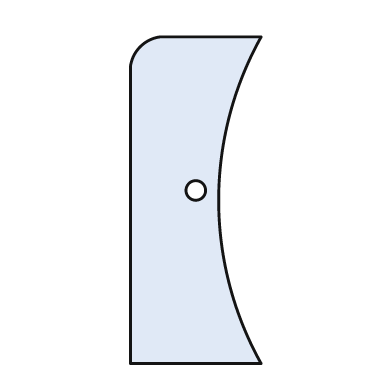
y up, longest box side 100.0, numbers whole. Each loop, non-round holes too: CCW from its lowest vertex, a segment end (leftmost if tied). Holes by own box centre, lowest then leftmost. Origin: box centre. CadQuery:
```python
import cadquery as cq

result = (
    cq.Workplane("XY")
    .moveTo(-20.0, -50.0)
    .lineTo(20.0, -50.0)
    .threePointArc((7.0, 0.0), (20.0, 50.0))
    .lineTo(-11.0, 50.0)
    .threePointArc((-17.0, 47.0), (-20.0, 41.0))
    .close()
    .moveTo(0.0, 3.0)
    .circle(3.0)
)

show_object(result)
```